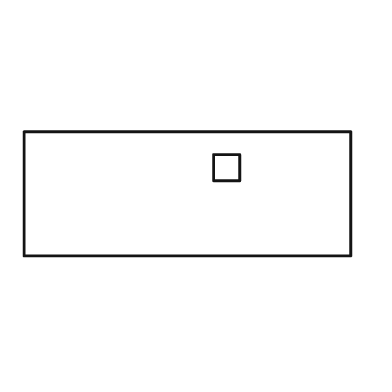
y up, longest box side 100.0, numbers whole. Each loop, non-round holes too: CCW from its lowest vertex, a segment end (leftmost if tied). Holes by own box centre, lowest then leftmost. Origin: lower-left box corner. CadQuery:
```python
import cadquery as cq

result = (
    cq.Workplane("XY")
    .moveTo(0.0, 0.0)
    .lineTo(100.0, 0.0)
    .lineTo(100.0, 38.0)
    .lineTo(0.0, 38.0)
    .close()
    .moveTo(58.0, 23.0)
    .lineTo(66.0, 23.0)
    .lineTo(66.0, 31.0)
    .lineTo(58.0, 31.0)
    .close()
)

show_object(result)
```